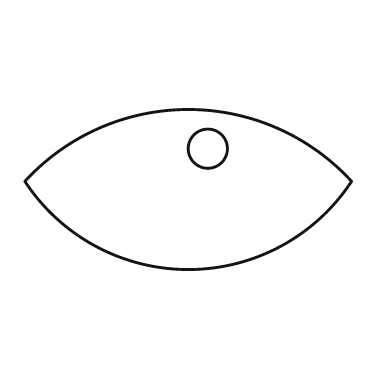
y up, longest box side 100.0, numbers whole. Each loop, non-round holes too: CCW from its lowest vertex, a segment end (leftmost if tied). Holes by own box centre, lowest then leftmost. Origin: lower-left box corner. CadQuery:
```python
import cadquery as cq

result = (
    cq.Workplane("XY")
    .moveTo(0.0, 27.0)
    .threePointArc((50.0, 0.0), (100.0, 27.0))
    .threePointArc((50.0, 49.0), (0.0, 27.0))
    .close()
    .moveTo(56.0, 37.0)
    .circle(6.0)
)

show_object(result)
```